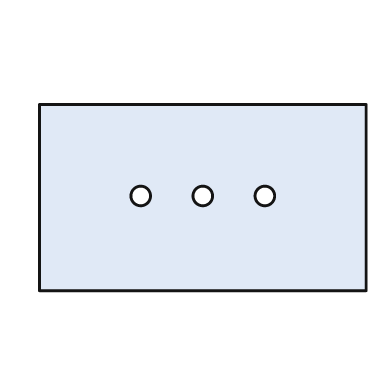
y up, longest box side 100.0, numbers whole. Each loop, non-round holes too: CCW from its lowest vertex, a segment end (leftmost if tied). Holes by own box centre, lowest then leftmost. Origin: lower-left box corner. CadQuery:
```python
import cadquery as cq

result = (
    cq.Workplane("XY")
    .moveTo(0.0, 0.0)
    .lineTo(100.0, 0.0)
    .lineTo(100.0, 57.0)
    .lineTo(0.0, 57.0)
    .close()
    .moveTo(31.0, 29.0)
    .circle(3.0)
    .moveTo(50.0, 29.0)
    .circle(3.0)
    .moveTo(69.0, 29.0)
    .circle(3.0)
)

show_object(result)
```